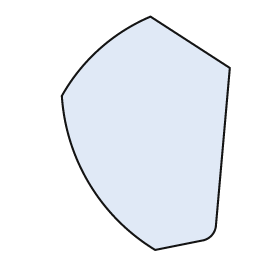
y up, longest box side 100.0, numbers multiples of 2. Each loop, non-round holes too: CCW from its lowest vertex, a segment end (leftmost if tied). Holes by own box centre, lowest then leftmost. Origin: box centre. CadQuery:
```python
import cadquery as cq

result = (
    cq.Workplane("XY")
    .moveTo(4.0, -50.0)
    .lineTo(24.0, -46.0)
    .threePointArc((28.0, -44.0), (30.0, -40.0))
    .lineTo(36.0, 28.0)
    .lineTo(2.0, 50.0)
    .threePointArc((-20.0, 36.0), (-36.0, 16.0))
    .threePointArc((-24.0, -22.0), (4.0, -50.0))
    .close()
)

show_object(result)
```